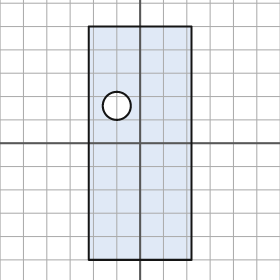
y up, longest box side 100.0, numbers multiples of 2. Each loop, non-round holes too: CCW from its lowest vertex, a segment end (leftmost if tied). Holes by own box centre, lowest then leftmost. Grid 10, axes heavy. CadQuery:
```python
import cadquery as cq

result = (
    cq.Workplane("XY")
    .moveTo(-22.0, -50.0)
    .lineTo(22.0, -50.0)
    .lineTo(22.0, 50.0)
    .lineTo(-22.0, 50.0)
    .close()
    .moveTo(-10.0, 16.0)
    .circle(6.0)
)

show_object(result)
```